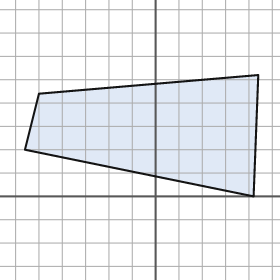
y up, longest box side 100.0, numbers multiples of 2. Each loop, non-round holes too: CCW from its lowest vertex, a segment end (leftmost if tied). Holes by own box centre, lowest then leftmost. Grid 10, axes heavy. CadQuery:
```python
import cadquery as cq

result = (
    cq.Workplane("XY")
    .moveTo(42.0, 0.0)
    .lineTo(44.0, 52.0)
    .lineTo(-50.0, 44.0)
    .lineTo(-56.0, 20.0)
    .close()
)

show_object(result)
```